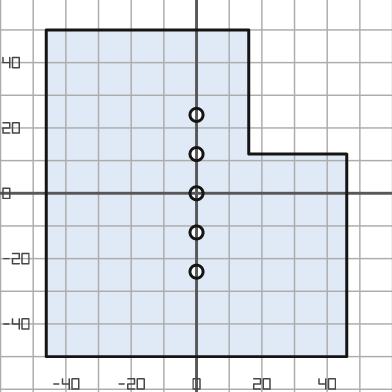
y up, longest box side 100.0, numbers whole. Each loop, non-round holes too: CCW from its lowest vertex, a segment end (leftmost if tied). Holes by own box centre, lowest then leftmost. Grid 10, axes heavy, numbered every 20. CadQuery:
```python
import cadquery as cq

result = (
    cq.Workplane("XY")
    .moveTo(-46.0, -50.0)
    .lineTo(46.0, -50.0)
    .lineTo(46.0, 12.0)
    .lineTo(16.0, 12.0)
    .lineTo(16.0, 50.0)
    .lineTo(-46.0, 50.0)
    .close()
    .moveTo(0.0, -24.0)
    .circle(2.0)
    .moveTo(0.0, -12.0)
    .circle(2.0)
    .moveTo(0.0, 0.0)
    .circle(2.0)
    .moveTo(0.0, 12.0)
    .circle(2.0)
    .moveTo(0.0, 24.0)
    .circle(2.0)
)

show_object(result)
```